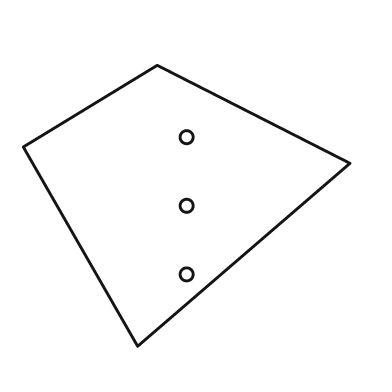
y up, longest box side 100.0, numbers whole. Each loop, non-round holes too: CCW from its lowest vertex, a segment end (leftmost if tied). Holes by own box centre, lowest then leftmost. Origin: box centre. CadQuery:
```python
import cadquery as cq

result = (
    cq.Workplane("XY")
    .moveTo(-15.0, -43.0)
    .lineTo(50.0, 13.0)
    .lineTo(-9.0, 43.0)
    .lineTo(-50.0, 18.0)
    .close()
    .moveTo(0.0, -21.0)
    .circle(2.0)
    .moveTo(0.0, 0.0)
    .circle(2.0)
    .moveTo(0.0, 21.0)
    .circle(2.0)
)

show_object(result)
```